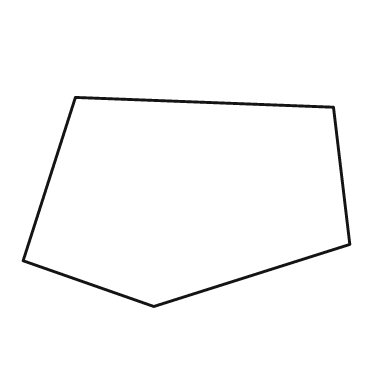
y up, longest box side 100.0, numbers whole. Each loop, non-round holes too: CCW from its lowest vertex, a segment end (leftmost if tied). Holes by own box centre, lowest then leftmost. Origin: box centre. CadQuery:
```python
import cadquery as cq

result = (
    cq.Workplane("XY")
    .moveTo(-10.0, -32.0)
    .lineTo(50.0, -13.0)
    .lineTo(45.0, 29.0)
    .lineTo(-34.0, 32.0)
    .lineTo(-50.0, -18.0)
    .close()
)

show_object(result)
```